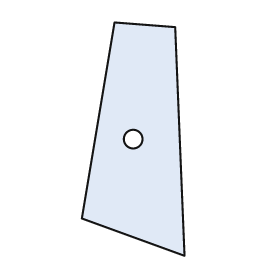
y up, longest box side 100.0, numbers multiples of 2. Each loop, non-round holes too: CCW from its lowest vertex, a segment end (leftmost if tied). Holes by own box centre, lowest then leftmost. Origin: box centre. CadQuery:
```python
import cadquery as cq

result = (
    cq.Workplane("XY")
    .moveTo(22.0, -50.0)
    .lineTo(18.0, 48.0)
    .lineTo(-8.0, 50.0)
    .lineTo(-22.0, -34.0)
    .close()
    .moveTo(0.0, 0.0)
    .circle(4.0)
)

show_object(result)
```